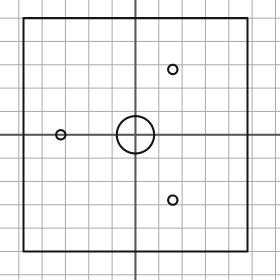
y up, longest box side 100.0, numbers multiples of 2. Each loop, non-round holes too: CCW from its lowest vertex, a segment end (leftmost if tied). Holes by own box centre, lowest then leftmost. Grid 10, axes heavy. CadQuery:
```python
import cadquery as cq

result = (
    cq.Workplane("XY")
    .moveTo(-48.0, -50.0)
    .lineTo(48.0, -50.0)
    .lineTo(48.0, 50.0)
    .lineTo(-48.0, 50.0)
    .close()
    .moveTo(16.0, -28.0)
    .circle(2.0)
    .moveTo(-32.0, 0.0)
    .circle(2.0)
    .moveTo(0.0, 0.0)
    .circle(8.0)
    .moveTo(16.0, 28.0)
    .circle(2.0)
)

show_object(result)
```